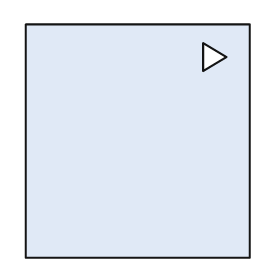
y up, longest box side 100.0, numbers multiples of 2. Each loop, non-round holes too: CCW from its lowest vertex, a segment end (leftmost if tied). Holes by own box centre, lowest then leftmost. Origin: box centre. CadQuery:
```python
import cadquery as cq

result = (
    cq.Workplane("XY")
    .moveTo(-48.0, -50.0)
    .lineTo(48.0, -50.0)
    .lineTo(48.0, 50.0)
    .lineTo(-48.0, 50.0)
    .close()
    .moveTo(28.0, 30.0)
    .lineTo(38.0, 36.0)
    .lineTo(28.0, 42.0)
    .close()
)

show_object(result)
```